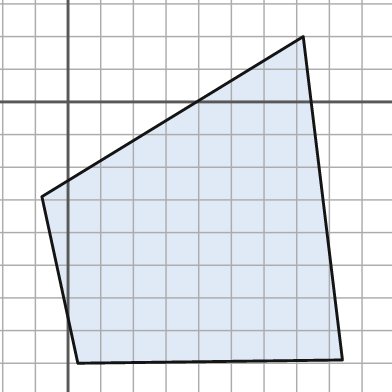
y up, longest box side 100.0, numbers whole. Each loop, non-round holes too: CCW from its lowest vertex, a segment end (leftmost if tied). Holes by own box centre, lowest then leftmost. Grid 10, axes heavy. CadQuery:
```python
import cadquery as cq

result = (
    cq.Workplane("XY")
    .moveTo(3.0, -80.0)
    .lineTo(84.0, -79.0)
    .lineTo(72.0, 20.0)
    .lineTo(-8.0, -29.0)
    .close()
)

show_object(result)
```